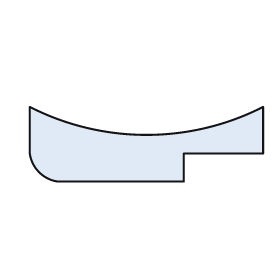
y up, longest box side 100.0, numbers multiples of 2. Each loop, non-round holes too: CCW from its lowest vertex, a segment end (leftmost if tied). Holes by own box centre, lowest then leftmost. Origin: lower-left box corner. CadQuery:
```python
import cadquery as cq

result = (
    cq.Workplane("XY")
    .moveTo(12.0, 0.0)
    .lineTo(66.0, 0.0)
    .lineTo(66.0, 12.0)
    .lineTo(100.0, 12.0)
    .lineTo(100.0, 32.0)
    .threePointArc((50.0, 20.0), (0.0, 32.0))
    .lineTo(0.0, 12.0)
    .threePointArc((4.0, 4.0), (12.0, 0.0))
    .close()
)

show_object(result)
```